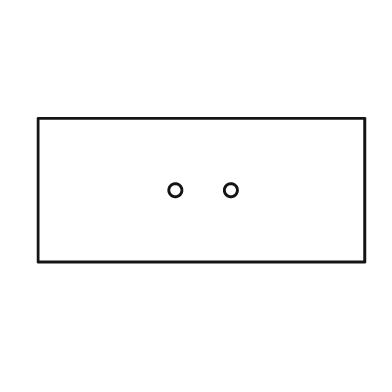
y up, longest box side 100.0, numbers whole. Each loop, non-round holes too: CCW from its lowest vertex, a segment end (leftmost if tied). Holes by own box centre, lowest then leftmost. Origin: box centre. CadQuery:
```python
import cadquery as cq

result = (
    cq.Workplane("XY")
    .moveTo(-50.0, -22.0)
    .lineTo(50.0, -22.0)
    .lineTo(50.0, 22.0)
    .lineTo(-50.0, 22.0)
    .close()
    .moveTo(-8.0, 0.0)
    .circle(2.0)
    .moveTo(9.0, 0.0)
    .circle(2.0)
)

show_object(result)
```